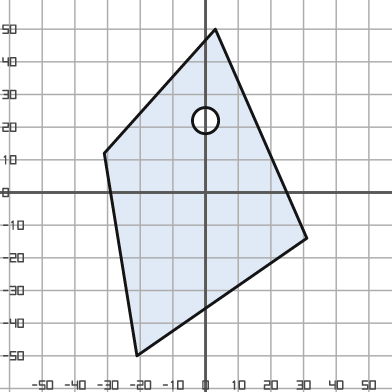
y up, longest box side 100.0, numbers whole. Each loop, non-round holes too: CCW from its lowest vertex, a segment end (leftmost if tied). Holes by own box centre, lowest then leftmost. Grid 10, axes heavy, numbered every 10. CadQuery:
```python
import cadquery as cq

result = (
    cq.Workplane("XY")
    .moveTo(-21.0, -50.0)
    .lineTo(31.0, -14.0)
    .lineTo(3.0, 50.0)
    .lineTo(-31.0, 12.0)
    .close()
    .moveTo(0.0, 22.0)
    .circle(4.0)
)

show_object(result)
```